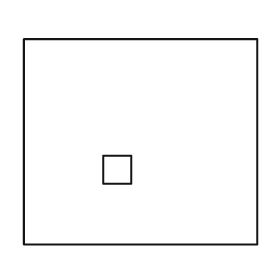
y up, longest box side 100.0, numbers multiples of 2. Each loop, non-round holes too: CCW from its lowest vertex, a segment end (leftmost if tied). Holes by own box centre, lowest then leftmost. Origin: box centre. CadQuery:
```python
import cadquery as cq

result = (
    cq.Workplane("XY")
    .moveTo(-50.0, -44.0)
    .lineTo(50.0, -44.0)
    .lineTo(50.0, 44.0)
    .lineTo(-50.0, 44.0)
    .close()
    .moveTo(-16.0, -18.0)
    .lineTo(-4.0, -18.0)
    .lineTo(-4.0, -6.0)
    .lineTo(-16.0, -6.0)
    .close()
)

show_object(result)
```